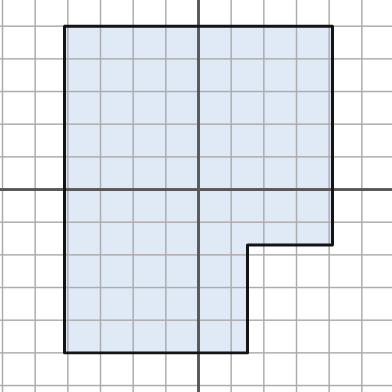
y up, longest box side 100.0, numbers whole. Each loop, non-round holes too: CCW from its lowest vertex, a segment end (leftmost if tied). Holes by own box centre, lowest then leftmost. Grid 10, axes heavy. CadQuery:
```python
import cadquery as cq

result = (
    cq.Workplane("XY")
    .moveTo(-41.0, -50.0)
    .lineTo(15.0, -50.0)
    .lineTo(15.0, -17.0)
    .lineTo(41.0, -17.0)
    .lineTo(41.0, 50.0)
    .lineTo(-41.0, 50.0)
    .close()
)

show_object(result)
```